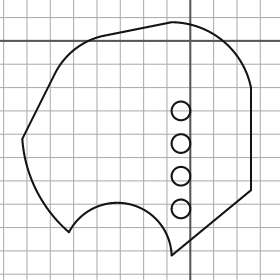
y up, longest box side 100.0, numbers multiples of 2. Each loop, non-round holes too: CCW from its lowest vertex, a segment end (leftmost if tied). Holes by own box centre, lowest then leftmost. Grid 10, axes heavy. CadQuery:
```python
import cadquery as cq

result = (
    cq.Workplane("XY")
    .moveTo(-8.0, -92.0)
    .lineTo(26.0, -64.0)
    .lineTo(26.0, -20.0)
    .threePointArc((14.0, 0.0), (-8.0, 8.0))
    .lineTo(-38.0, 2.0)
    .threePointArc((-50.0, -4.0), (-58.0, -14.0))
    .lineTo(-72.0, -42.0)
    .threePointArc((-66.0, -64.0), (-52.0, -82.0))
    .threePointArc((-26.0, -70.0), (-8.0, -92.0))
    .close()
    .moveTo(-4.0, -72.0)
    .circle(4.0)
    .moveTo(-4.0, -58.0)
    .circle(4.0)
    .moveTo(-4.0, -44.0)
    .circle(4.0)
    .moveTo(-4.0, -30.0)
    .circle(4.0)
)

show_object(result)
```